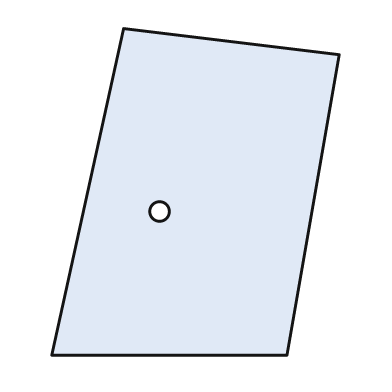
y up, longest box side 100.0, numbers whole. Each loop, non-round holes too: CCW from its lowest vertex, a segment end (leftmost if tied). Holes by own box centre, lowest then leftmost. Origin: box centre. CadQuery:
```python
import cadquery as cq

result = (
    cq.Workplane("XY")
    .moveTo(-44.0, -50.0)
    .lineTo(28.0, -50.0)
    .lineTo(44.0, 42.0)
    .lineTo(-22.0, 50.0)
    .close()
    .moveTo(-11.0, -6.0)
    .circle(3.0)
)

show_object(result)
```